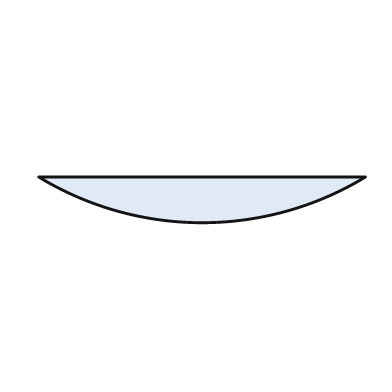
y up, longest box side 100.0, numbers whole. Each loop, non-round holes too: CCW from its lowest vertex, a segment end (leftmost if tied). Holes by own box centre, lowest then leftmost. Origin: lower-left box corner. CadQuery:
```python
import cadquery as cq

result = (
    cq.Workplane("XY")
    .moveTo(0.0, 14.0)
    .threePointArc((50.0, 0.0), (100.0, 14.0))
    .close()
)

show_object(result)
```